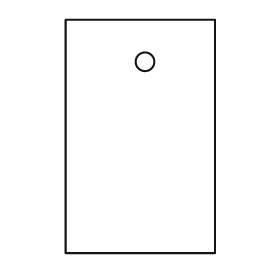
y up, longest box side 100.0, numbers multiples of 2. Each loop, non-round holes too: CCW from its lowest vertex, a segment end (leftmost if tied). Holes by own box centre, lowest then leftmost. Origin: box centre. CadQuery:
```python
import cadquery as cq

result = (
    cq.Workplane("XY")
    .moveTo(-32.0, -50.0)
    .lineTo(32.0, -50.0)
    .lineTo(32.0, 50.0)
    .lineTo(-32.0, 50.0)
    .close()
    .moveTo(2.0, 32.0)
    .circle(4.0)
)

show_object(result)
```